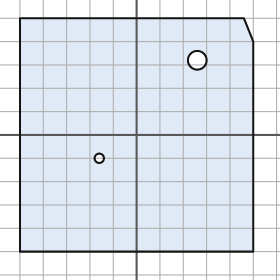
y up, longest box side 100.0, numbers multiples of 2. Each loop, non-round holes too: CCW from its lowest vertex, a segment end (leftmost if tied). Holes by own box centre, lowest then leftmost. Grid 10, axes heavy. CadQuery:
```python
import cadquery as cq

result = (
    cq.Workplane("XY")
    .moveTo(-50.0, -50.0)
    .lineTo(50.0, -50.0)
    .lineTo(50.0, 40.0)
    .lineTo(46.0, 50.0)
    .lineTo(-50.0, 50.0)
    .close()
    .moveTo(-16.0, -10.0)
    .circle(2.0)
    .moveTo(26.0, 32.0)
    .circle(4.0)
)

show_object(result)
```